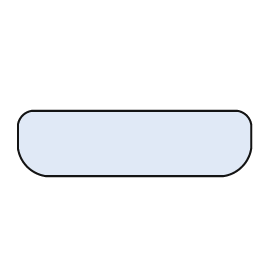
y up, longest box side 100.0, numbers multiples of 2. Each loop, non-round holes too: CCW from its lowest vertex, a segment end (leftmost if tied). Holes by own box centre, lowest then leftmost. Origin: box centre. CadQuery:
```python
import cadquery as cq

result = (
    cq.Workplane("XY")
    .moveTo(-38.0, -14.0)
    .lineTo(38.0, -14.0)
    .threePointArc((46.0, -10.0), (50.0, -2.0))
    .lineTo(50.0, 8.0)
    .threePointArc((48.0, 12.0), (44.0, 14.0))
    .lineTo(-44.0, 14.0)
    .threePointArc((-48.0, 12.0), (-50.0, 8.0))
    .lineTo(-50.0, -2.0)
    .threePointArc((-46.0, -10.0), (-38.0, -14.0))
    .close()
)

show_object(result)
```